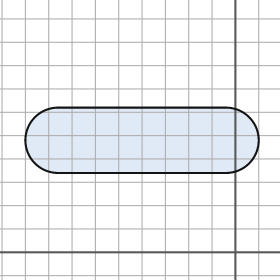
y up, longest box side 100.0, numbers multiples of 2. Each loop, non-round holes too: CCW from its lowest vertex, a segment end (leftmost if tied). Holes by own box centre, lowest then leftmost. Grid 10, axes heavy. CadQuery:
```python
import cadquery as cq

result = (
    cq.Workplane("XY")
    .moveTo(-76.0, 34.0)
    .lineTo(-4.0, 34.0)
    .threePointArc((10.0, 48.0), (-4.0, 62.0))
    .lineTo(-76.0, 62.0)
    .threePointArc((-90.0, 48.0), (-76.0, 34.0))
    .close()
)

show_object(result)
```